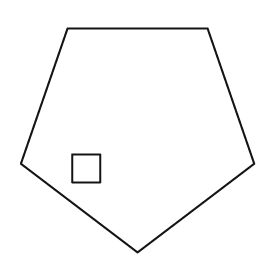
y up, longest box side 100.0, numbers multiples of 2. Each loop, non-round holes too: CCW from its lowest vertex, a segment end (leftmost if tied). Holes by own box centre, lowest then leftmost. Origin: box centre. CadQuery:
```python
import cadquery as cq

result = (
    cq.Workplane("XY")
    .moveTo(0.0, -48.0)
    .lineTo(50.0, -10.0)
    .lineTo(30.0, 48.0)
    .lineTo(-30.0, 48.0)
    .lineTo(-50.0, -10.0)
    .close()
    .moveTo(-28.0, -18.0)
    .lineTo(-16.0, -18.0)
    .lineTo(-16.0, -6.0)
    .lineTo(-28.0, -6.0)
    .close()
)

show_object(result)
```